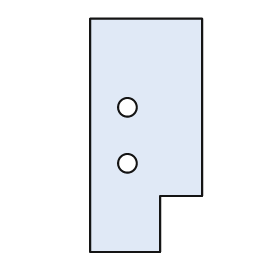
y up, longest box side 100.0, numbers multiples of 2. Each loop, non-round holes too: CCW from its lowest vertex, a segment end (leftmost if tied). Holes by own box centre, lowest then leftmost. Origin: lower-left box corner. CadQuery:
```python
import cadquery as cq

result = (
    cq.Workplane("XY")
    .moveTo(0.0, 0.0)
    .lineTo(30.0, 0.0)
    .lineTo(30.0, 24.0)
    .lineTo(48.0, 24.0)
    .lineTo(48.0, 100.0)
    .lineTo(0.0, 100.0)
    .close()
    .moveTo(16.0, 38.0)
    .circle(4.0)
    .moveTo(16.0, 62.0)
    .circle(4.0)
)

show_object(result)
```